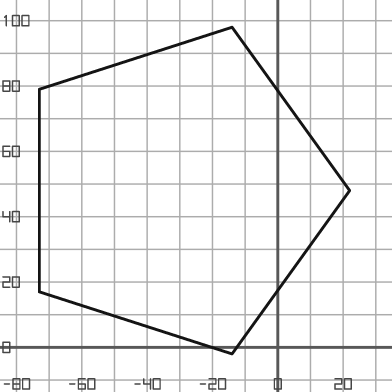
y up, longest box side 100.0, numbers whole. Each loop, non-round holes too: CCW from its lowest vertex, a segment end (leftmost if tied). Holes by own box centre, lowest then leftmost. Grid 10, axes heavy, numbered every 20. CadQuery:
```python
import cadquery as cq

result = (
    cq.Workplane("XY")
    .moveTo(-14.0, -2.0)
    .lineTo(22.0, 48.0)
    .lineTo(-14.0, 98.0)
    .lineTo(-73.0, 79.0)
    .lineTo(-73.0, 17.0)
    .close()
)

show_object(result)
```